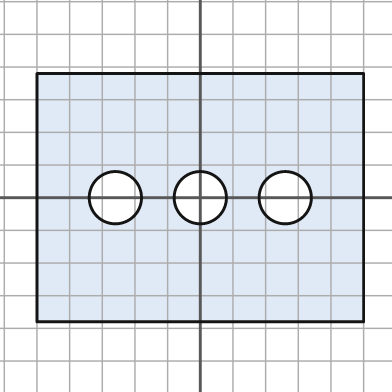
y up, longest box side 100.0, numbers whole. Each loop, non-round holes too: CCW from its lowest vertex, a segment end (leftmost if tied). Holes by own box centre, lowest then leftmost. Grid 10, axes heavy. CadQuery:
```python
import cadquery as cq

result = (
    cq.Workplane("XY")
    .moveTo(-50.0, -38.0)
    .lineTo(50.0, -38.0)
    .lineTo(50.0, 38.0)
    .lineTo(-50.0, 38.0)
    .close()
    .moveTo(-26.0, 0.0)
    .circle(8.0)
    .moveTo(0.0, 0.0)
    .circle(8.0)
    .moveTo(26.0, 0.0)
    .circle(8.0)
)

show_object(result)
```